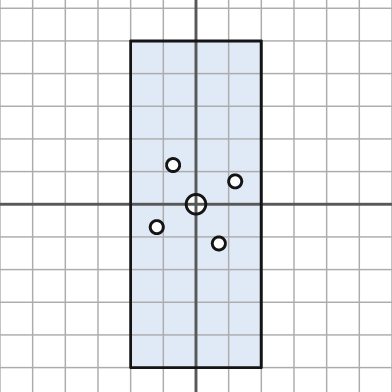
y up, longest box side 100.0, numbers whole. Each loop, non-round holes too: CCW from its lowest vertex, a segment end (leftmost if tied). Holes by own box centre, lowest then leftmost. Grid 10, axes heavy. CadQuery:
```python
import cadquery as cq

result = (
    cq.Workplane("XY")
    .moveTo(-20.0, -50.0)
    .lineTo(20.0, -50.0)
    .lineTo(20.0, 50.0)
    .lineTo(-20.0, 50.0)
    .close()
    .moveTo(7.0, -12.0)
    .circle(2.0)
    .moveTo(-12.0, -7.0)
    .circle(2.0)
    .moveTo(0.0, 0.0)
    .circle(3.0)
    .moveTo(12.0, 7.0)
    .circle(2.0)
    .moveTo(-7.0, 12.0)
    .circle(2.0)
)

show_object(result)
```